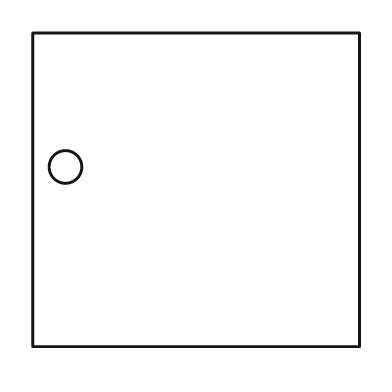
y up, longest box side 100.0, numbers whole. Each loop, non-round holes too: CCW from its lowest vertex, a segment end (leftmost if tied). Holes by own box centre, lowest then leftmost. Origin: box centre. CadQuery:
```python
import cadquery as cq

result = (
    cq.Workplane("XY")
    .moveTo(-50.0, -48.0)
    .lineTo(50.0, -48.0)
    .lineTo(50.0, 48.0)
    .lineTo(-50.0, 48.0)
    .close()
    .moveTo(-40.0, 7.0)
    .circle(5.0)
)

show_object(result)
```